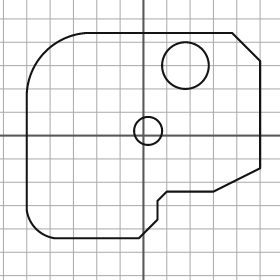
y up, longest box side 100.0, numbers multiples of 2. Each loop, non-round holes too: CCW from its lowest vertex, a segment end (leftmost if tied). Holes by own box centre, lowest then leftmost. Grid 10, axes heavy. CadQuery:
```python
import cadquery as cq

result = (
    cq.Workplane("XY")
    .moveTo(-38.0, -44.0)
    .lineTo(-2.0, -44.0)
    .lineTo(6.0, -36.0)
    .lineTo(6.0, -28.0)
    .lineTo(10.0, -24.0)
    .lineTo(30.0, -24.0)
    .lineTo(50.0, -14.0)
    .lineTo(50.0, 32.0)
    .lineTo(38.0, 44.0)
    .lineTo(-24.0, 44.0)
    .threePointArc((-42.0, 36.0), (-50.0, 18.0))
    .lineTo(-50.0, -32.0)
    .threePointArc((-46.0, -40.0), (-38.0, -44.0))
    .close()
    .moveTo(2.0, 2.0)
    .circle(6.0)
    .moveTo(18.0, 30.0)
    .circle(10.0)
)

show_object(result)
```